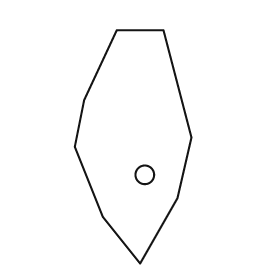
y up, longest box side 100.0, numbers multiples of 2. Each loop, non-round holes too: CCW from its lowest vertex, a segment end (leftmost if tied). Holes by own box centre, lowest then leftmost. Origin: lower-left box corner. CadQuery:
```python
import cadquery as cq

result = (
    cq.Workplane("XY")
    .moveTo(28.0, 0.0)
    .lineTo(44.0, 28.0)
    .lineTo(50.0, 54.0)
    .lineTo(38.0, 100.0)
    .lineTo(18.0, 100.0)
    .lineTo(4.0, 70.0)
    .lineTo(0.0, 50.0)
    .lineTo(12.0, 20.0)
    .close()
    .moveTo(30.0, 38.0)
    .circle(4.0)
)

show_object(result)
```